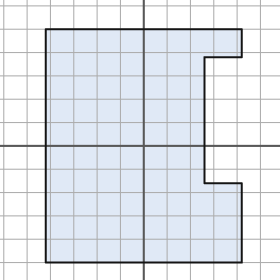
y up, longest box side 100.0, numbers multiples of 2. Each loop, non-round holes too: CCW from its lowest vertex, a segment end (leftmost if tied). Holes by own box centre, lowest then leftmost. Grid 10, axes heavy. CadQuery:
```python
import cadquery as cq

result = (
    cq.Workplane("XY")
    .moveTo(-42.0, -50.0)
    .lineTo(42.0, -50.0)
    .lineTo(42.0, -16.0)
    .lineTo(26.0, -16.0)
    .lineTo(26.0, 38.0)
    .lineTo(42.0, 38.0)
    .lineTo(42.0, 50.0)
    .lineTo(-42.0, 50.0)
    .close()
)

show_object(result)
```